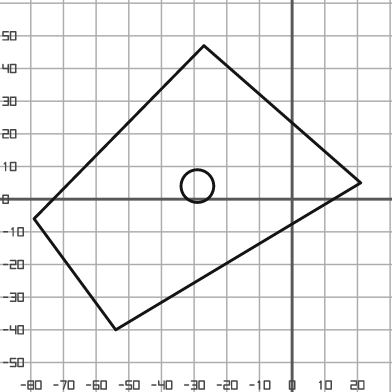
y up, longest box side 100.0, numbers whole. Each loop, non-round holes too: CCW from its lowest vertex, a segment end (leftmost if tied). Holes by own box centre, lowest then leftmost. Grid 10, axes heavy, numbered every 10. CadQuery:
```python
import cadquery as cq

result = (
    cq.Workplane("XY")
    .moveTo(-54.0, -40.0)
    .lineTo(21.0, 5.0)
    .lineTo(-27.0, 47.0)
    .lineTo(-79.0, -6.0)
    .close()
    .moveTo(-29.0, 4.0)
    .circle(5.0)
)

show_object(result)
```